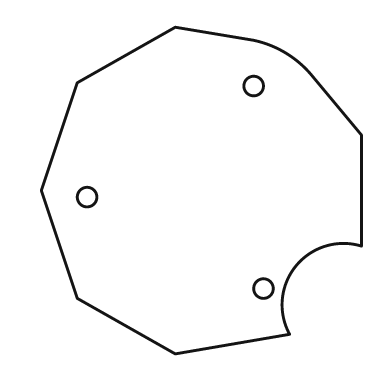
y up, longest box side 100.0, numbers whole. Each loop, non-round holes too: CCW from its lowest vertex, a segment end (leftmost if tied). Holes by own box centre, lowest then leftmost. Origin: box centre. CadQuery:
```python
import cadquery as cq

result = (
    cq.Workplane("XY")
    .moveTo(-8.0, -50.0)
    .lineTo(27.0, -44.0)
    .threePointArc((29.0, -23.0), (49.0, -17.0))
    .lineTo(49.0, 17.0)
    .lineTo(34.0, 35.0)
    .threePointArc((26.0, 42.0), (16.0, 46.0))
    .lineTo(-8.0, 50.0)
    .lineTo(-38.0, 33.0)
    .lineTo(-49.0, 0.0)
    .lineTo(-38.0, -33.0)
    .close()
    .moveTo(19.0, -30.0)
    .circle(3.0)
    .moveTo(-35.0, -2.0)
    .circle(3.0)
    .moveTo(16.0, 32.0)
    .circle(3.0)
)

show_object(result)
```